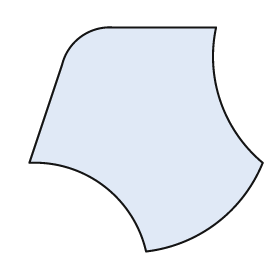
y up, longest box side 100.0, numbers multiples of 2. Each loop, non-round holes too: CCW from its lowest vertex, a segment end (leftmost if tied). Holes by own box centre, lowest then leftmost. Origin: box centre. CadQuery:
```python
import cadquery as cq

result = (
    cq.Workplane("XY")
    .moveTo(0.0, -48.0)
    .threePointArc((30.0, -36.0), (50.0, -10.0))
    .threePointArc((32.0, 16.0), (30.0, 48.0))
    .lineTo(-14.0, 48.0)
    .threePointArc((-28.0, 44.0), (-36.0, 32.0))
    .lineTo(-50.0, -10.0)
    .threePointArc((-18.0, -20.0), (0.0, -48.0))
    .close()
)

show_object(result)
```